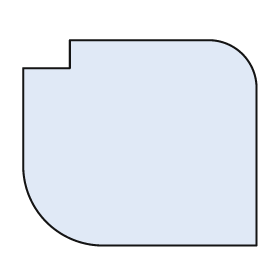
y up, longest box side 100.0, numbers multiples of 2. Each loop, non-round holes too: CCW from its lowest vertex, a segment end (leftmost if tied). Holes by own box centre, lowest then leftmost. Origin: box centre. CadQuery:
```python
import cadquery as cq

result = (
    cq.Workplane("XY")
    .moveTo(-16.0, -44.0)
    .lineTo(50.0, -44.0)
    .lineTo(50.0, 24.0)
    .threePointArc((44.0, 38.0), (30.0, 44.0))
    .lineTo(-30.0, 44.0)
    .lineTo(-30.0, 32.0)
    .lineTo(-50.0, 32.0)
    .lineTo(-50.0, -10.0)
    .threePointArc((-40.0, -34.0), (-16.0, -44.0))
    .close()
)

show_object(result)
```